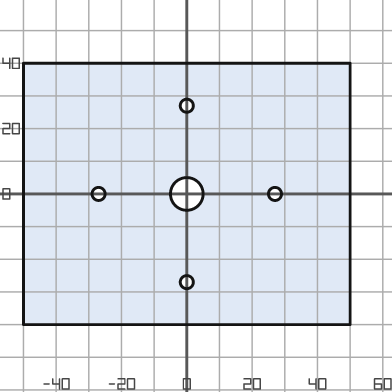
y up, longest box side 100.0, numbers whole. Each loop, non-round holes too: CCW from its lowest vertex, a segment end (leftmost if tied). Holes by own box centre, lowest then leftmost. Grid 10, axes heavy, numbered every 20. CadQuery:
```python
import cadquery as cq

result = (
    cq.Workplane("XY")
    .moveTo(-50.0, -40.0)
    .lineTo(50.0, -40.0)
    .lineTo(50.0, 40.0)
    .lineTo(-50.0, 40.0)
    .close()
    .moveTo(0.0, -27.0)
    .circle(2.0)
    .moveTo(-27.0, 0.0)
    .circle(2.0)
    .moveTo(0.0, 0.0)
    .circle(5.0)
    .moveTo(27.0, 0.0)
    .circle(2.0)
    .moveTo(0.0, 27.0)
    .circle(2.0)
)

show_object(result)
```